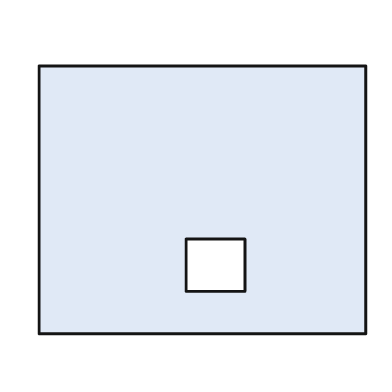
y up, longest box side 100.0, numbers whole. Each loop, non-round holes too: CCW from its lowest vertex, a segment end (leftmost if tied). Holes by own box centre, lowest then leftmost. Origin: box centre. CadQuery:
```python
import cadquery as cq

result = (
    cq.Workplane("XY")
    .moveTo(-50.0, -41.0)
    .lineTo(50.0, -41.0)
    .lineTo(50.0, 41.0)
    .lineTo(-50.0, 41.0)
    .close()
    .moveTo(-5.0, -28.0)
    .lineTo(13.0, -28.0)
    .lineTo(13.0, -12.0)
    .lineTo(-5.0, -12.0)
    .close()
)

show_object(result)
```